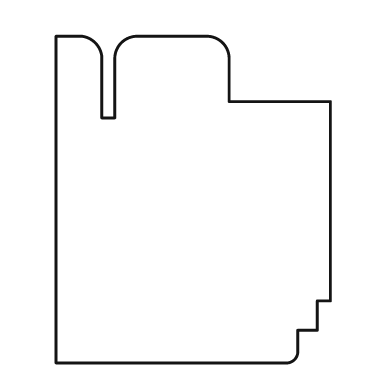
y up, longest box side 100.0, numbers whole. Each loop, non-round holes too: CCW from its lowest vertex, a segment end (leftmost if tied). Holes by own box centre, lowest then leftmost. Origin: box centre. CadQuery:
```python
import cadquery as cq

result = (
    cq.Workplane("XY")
    .moveTo(-42.0, -50.0)
    .lineTo(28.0, -50.0)
    .threePointArc((31.0, -49.0), (32.0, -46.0))
    .lineTo(32.0, -40.0)
    .lineTo(38.0, -40.0)
    .lineTo(38.0, -31.0)
    .lineTo(42.0, -31.0)
    .lineTo(42.0, 30.0)
    .lineTo(11.0, 30.0)
    .lineTo(11.0, 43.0)
    .threePointArc((9.0, 48.0), (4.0, 50.0))
    .lineTo(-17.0, 50.0)
    .threePointArc((-22.0, 48.0), (-24.0, 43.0))
    .lineTo(-24.0, 25.0)
    .lineTo(-28.0, 25.0)
    .lineTo(-28.0, 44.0)
    .threePointArc((-30.0, 48.0), (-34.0, 50.0))
    .lineTo(-42.0, 50.0)
    .close()
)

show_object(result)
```